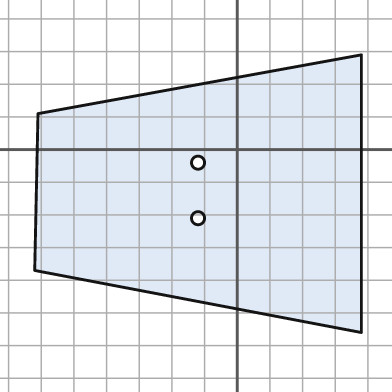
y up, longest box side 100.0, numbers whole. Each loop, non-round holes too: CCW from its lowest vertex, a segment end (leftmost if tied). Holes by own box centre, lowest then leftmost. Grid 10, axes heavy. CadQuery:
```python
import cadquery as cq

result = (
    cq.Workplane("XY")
    .moveTo(38.0, -56.0)
    .lineTo(38.0, 29.0)
    .lineTo(-61.0, 11.0)
    .lineTo(-62.0, -37.0)
    .close()
    .moveTo(-12.0, -21.0)
    .circle(2.0)
    .moveTo(-12.0, -4.0)
    .circle(2.0)
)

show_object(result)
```